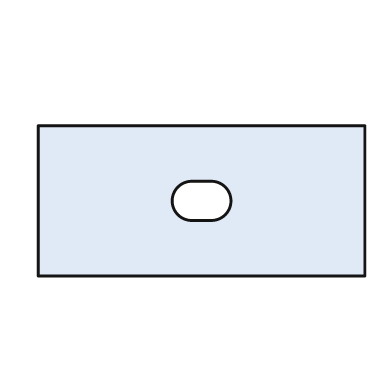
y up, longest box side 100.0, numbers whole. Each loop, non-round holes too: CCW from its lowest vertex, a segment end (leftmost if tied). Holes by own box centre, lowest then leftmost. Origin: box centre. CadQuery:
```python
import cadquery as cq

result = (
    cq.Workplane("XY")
    .moveTo(-50.0, -23.0)
    .lineTo(50.0, -23.0)
    .lineTo(50.0, 23.0)
    .lineTo(-50.0, 23.0)
    .close()
    .moveTo(-3.0, -6.0)
    .lineTo(3.0, -6.0)
    .threePointArc((9.0, 0.0), (3.0, 6.0))
    .lineTo(-3.0, 6.0)
    .threePointArc((-9.0, 0.0), (-3.0, -6.0))
    .close()
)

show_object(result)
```